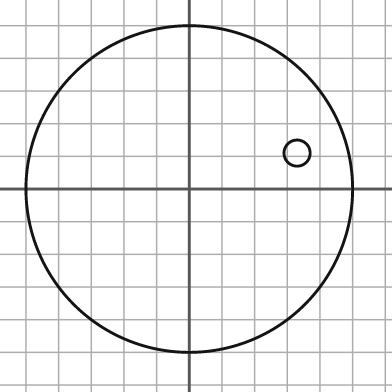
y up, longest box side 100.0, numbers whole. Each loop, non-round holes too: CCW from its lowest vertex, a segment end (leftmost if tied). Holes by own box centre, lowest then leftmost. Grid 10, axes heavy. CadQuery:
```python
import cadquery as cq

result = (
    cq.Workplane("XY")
    .moveTo(0.0, 0.0)
    .circle(50.0)
    .moveTo(33.0, 11.0)
    .circle(4.0)
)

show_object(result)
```